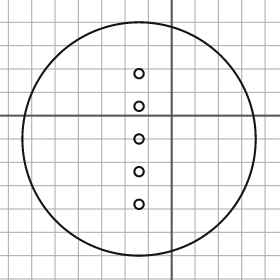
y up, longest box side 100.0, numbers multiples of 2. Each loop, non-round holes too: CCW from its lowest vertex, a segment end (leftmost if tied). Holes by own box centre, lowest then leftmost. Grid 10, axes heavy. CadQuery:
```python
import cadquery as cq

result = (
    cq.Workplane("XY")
    .moveTo(-14.0, -10.0)
    .circle(50.0)
    .moveTo(-14.0, -38.0)
    .circle(2.0)
    .moveTo(-14.0, -24.0)
    .circle(2.0)
    .moveTo(-14.0, -10.0)
    .circle(2.0)
    .moveTo(-14.0, 4.0)
    .circle(2.0)
    .moveTo(-14.0, 18.0)
    .circle(2.0)
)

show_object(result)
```